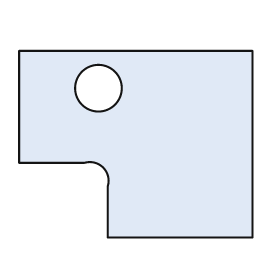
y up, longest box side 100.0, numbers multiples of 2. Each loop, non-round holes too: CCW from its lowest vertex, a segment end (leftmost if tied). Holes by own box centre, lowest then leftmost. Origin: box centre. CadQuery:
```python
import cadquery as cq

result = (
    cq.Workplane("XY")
    .moveTo(-12.0, -40.0)
    .lineTo(50.0, -40.0)
    .lineTo(50.0, 40.0)
    .lineTo(-50.0, 40.0)
    .lineTo(-50.0, -8.0)
    .lineTo(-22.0, -8.0)
    .threePointArc((-14.0, -10.0), (-12.0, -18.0))
    .close()
    .moveTo(-16.0, 24.0)
    .circle(10.0)
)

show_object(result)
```